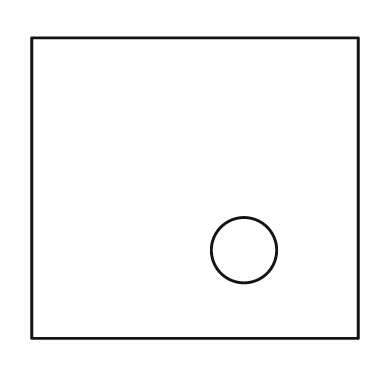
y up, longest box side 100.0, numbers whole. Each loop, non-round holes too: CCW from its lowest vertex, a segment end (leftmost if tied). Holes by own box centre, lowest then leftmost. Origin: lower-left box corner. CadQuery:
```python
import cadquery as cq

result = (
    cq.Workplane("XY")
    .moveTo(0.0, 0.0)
    .lineTo(100.0, 0.0)
    .lineTo(100.0, 92.0)
    .lineTo(0.0, 92.0)
    .close()
    .moveTo(65.0, 27.0)
    .circle(10.0)
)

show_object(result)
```